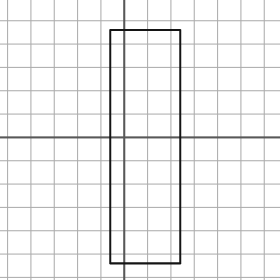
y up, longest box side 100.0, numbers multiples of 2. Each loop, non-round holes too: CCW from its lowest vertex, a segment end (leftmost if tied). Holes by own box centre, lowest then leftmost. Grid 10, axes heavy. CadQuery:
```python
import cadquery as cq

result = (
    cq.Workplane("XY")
    .moveTo(-6.0, -54.0)
    .lineTo(24.0, -54.0)
    .lineTo(24.0, 46.0)
    .lineTo(-6.0, 46.0)
    .close()
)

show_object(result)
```